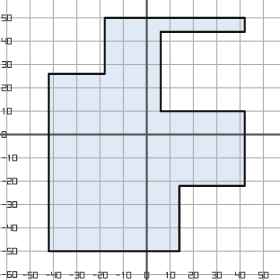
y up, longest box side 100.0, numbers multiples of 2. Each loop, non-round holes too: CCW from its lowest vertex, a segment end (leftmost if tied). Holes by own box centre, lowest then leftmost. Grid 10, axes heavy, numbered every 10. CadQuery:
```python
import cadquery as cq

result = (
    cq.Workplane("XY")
    .moveTo(-42.0, -50.0)
    .lineTo(14.0, -50.0)
    .lineTo(14.0, -22.0)
    .lineTo(42.0, -22.0)
    .lineTo(42.0, 10.0)
    .lineTo(6.0, 10.0)
    .lineTo(6.0, 44.0)
    .lineTo(42.0, 44.0)
    .lineTo(42.0, 50.0)
    .lineTo(-18.0, 50.0)
    .lineTo(-18.0, 26.0)
    .lineTo(-42.0, 26.0)
    .close()
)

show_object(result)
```